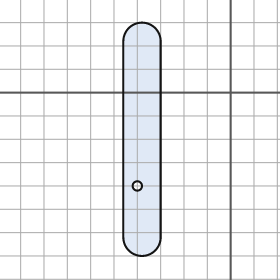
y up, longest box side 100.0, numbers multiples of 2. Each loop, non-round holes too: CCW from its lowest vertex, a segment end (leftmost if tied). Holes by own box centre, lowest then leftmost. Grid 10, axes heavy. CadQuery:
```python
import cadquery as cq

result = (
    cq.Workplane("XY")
    .moveTo(-46.0, -62.0)
    .threePointArc((-38.0, -70.0), (-30.0, -62.0))
    .lineTo(-30.0, 22.0)
    .threePointArc((-38.0, 30.0), (-46.0, 22.0))
    .close()
    .moveTo(-40.0, -40.0)
    .circle(2.0)
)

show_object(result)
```